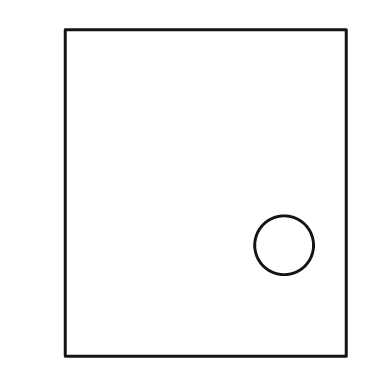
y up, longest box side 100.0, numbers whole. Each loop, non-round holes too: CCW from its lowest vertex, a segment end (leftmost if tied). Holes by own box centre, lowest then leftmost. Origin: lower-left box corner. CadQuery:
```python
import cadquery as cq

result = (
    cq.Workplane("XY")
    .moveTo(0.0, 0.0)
    .lineTo(86.0, 0.0)
    .lineTo(86.0, 100.0)
    .lineTo(0.0, 100.0)
    .close()
    .moveTo(67.0, 34.0)
    .circle(9.0)
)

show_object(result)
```